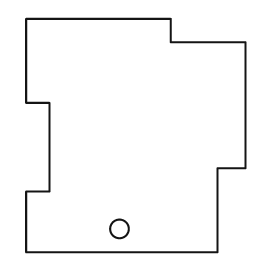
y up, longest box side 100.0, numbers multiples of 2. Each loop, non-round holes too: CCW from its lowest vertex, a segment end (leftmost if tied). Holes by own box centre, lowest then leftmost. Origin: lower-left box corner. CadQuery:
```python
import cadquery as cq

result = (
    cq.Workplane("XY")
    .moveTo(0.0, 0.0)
    .lineTo(82.0, 0.0)
    .lineTo(82.0, 36.0)
    .lineTo(94.0, 36.0)
    .lineTo(94.0, 90.0)
    .lineTo(62.0, 90.0)
    .lineTo(62.0, 100.0)
    .lineTo(0.0, 100.0)
    .lineTo(0.0, 64.0)
    .lineTo(10.0, 64.0)
    .lineTo(10.0, 26.0)
    .lineTo(0.0, 26.0)
    .close()
    .moveTo(40.0, 10.0)
    .circle(4.0)
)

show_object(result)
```